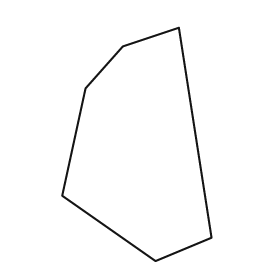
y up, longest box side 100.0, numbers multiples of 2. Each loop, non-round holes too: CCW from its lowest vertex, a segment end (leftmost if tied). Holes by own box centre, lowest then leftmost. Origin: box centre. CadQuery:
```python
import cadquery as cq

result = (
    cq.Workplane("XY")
    .moveTo(8.0, -50.0)
    .lineTo(32.0, -40.0)
    .lineTo(18.0, 50.0)
    .lineTo(-6.0, 42.0)
    .lineTo(-22.0, 24.0)
    .lineTo(-32.0, -22.0)
    .close()
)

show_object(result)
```